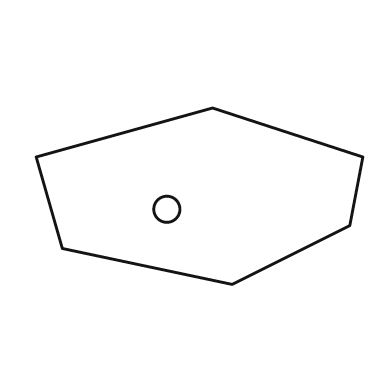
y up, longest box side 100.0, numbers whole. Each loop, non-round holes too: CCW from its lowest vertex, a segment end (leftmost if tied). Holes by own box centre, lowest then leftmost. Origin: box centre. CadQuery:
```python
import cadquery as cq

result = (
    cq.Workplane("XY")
    .moveTo(10.0, -27.0)
    .lineTo(46.0, -9.0)
    .lineTo(50.0, 12.0)
    .lineTo(4.0, 27.0)
    .lineTo(-50.0, 12.0)
    .lineTo(-42.0, -16.0)
    .close()
    .moveTo(-10.0, -4.0)
    .circle(4.0)
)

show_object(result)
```